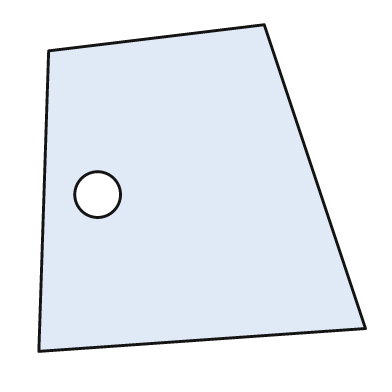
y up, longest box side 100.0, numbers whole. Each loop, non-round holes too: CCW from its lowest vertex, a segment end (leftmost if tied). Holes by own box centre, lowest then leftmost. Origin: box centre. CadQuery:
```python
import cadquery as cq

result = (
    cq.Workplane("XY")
    .moveTo(-50.0, -50.0)
    .lineTo(50.0, -43.0)
    .lineTo(19.0, 50.0)
    .lineTo(-47.0, 42.0)
    .close()
    .moveTo(-32.0, -2.0)
    .circle(7.0)
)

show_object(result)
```